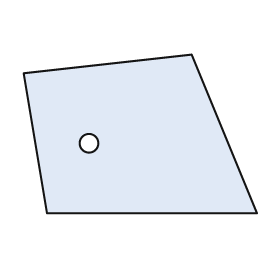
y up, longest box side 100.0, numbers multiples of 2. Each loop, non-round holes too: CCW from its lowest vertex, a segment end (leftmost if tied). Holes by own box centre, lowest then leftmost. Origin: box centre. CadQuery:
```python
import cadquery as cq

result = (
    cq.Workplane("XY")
    .moveTo(-40.0, -34.0)
    .lineTo(50.0, -34.0)
    .lineTo(22.0, 34.0)
    .lineTo(-50.0, 26.0)
    .close()
    .moveTo(-22.0, -4.0)
    .circle(4.0)
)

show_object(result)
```